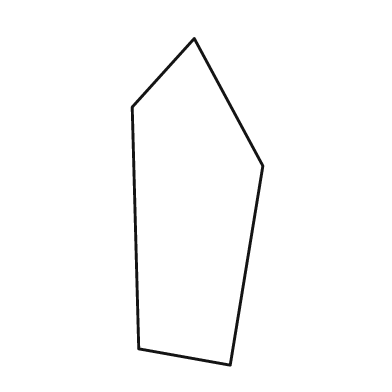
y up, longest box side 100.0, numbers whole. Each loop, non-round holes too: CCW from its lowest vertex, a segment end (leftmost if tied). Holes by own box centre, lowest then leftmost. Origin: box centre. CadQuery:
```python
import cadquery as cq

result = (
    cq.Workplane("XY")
    .moveTo(10.0, -50.0)
    .lineTo(20.0, 11.0)
    .lineTo(-1.0, 50.0)
    .lineTo(-20.0, 29.0)
    .lineTo(-18.0, -45.0)
    .close()
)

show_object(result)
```